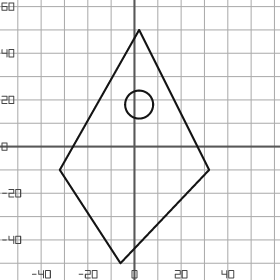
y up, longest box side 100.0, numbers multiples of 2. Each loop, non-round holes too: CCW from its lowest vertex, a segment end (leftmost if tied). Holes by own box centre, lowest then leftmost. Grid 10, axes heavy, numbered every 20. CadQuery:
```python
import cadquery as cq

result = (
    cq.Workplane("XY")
    .moveTo(-6.0, -50.0)
    .lineTo(32.0, -10.0)
    .lineTo(2.0, 50.0)
    .lineTo(-32.0, -10.0)
    .close()
    .moveTo(2.0, 18.0)
    .circle(6.0)
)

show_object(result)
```